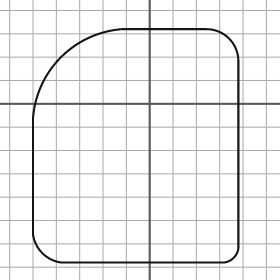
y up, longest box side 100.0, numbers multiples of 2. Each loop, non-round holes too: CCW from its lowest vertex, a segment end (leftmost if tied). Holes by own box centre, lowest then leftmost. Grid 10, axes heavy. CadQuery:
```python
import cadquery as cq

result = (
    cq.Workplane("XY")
    .moveTo(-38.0, -68.0)
    .lineTo(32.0, -68.0)
    .threePointArc((36.0, -66.0), (38.0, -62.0))
    .lineTo(38.0, 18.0)
    .threePointArc((34.0, 28.0), (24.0, 32.0))
    .lineTo(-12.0, 32.0)
    .threePointArc((-38.0, 20.0), (-50.0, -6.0))
    .lineTo(-50.0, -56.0)
    .threePointArc((-46.0, -64.0), (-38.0, -68.0))
    .close()
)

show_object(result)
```